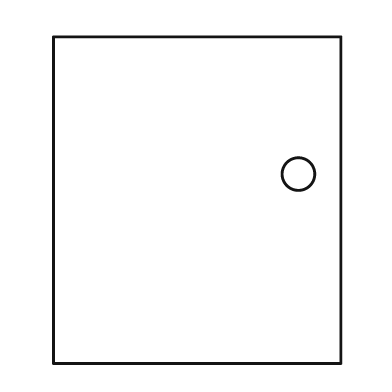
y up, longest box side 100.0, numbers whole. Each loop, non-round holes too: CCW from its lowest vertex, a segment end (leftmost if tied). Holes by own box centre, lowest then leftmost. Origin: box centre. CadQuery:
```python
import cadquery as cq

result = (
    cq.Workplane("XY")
    .moveTo(-44.0, -50.0)
    .lineTo(44.0, -50.0)
    .lineTo(44.0, 50.0)
    .lineTo(-44.0, 50.0)
    .close()
    .moveTo(31.0, 8.0)
    .circle(5.0)
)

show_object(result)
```